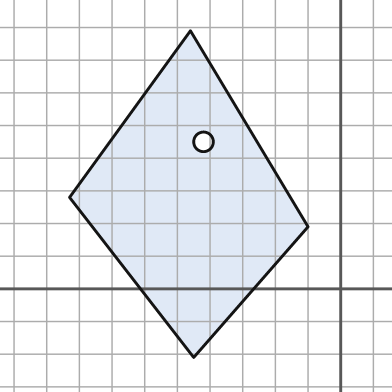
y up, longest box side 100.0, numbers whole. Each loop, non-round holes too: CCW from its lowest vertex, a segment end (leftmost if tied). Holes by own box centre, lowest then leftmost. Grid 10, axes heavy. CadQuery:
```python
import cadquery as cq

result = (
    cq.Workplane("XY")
    .moveTo(-45.0, -21.0)
    .lineTo(-10.0, 19.0)
    .lineTo(-46.0, 79.0)
    .lineTo(-83.0, 28.0)
    .close()
    .moveTo(-42.0, 45.0)
    .circle(3.0)
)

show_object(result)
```